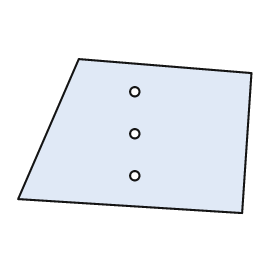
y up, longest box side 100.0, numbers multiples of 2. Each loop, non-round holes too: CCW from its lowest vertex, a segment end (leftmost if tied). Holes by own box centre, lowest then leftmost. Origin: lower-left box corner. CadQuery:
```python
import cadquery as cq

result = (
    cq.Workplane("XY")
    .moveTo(96.0, 0.0)
    .lineTo(100.0, 60.0)
    .lineTo(26.0, 66.0)
    .lineTo(0.0, 6.0)
    .close()
    .moveTo(50.0, 16.0)
    .circle(2.0)
    .moveTo(50.0, 34.0)
    .circle(2.0)
    .moveTo(50.0, 52.0)
    .circle(2.0)
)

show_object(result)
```